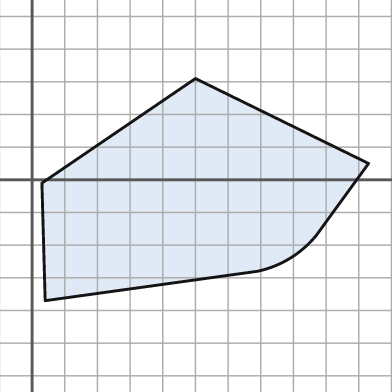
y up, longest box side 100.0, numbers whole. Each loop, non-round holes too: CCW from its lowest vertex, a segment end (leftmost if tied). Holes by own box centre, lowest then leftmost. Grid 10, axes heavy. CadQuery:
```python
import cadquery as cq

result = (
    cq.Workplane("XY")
    .moveTo(4.0, -37.0)
    .lineTo(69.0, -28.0)
    .threePointArc((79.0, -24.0), (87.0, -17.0))
    .lineTo(103.0, 5.0)
    .lineTo(50.0, 31.0)
    .lineTo(3.0, -1.0)
    .close()
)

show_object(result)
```